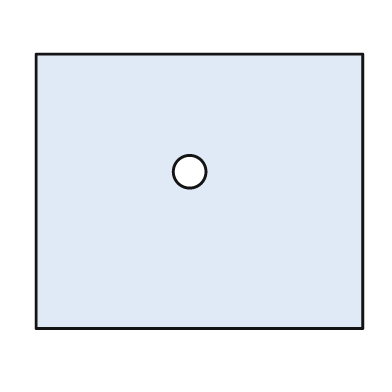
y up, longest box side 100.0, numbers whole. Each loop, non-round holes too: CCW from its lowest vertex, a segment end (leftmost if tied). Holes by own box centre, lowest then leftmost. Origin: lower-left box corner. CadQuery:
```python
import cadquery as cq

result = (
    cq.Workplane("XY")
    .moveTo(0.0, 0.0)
    .lineTo(100.0, 0.0)
    .lineTo(100.0, 84.0)
    .lineTo(0.0, 84.0)
    .close()
    .moveTo(47.0, 48.0)
    .circle(5.0)
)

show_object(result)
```